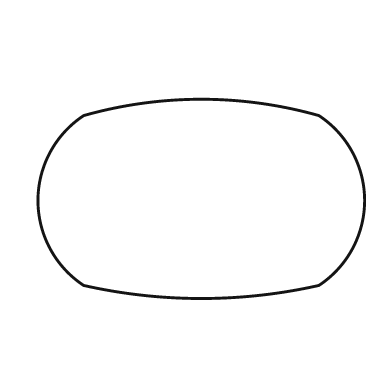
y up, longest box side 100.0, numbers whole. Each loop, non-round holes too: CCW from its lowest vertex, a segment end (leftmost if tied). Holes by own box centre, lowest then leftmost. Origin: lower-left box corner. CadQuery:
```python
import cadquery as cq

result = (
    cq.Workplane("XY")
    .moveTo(14.0, 4.0)
    .threePointArc((50.0, 0.0), (86.0, 4.0))
    .threePointArc((100.0, 30.0), (86.0, 56.0))
    .threePointArc((50.0, 61.0), (14.0, 56.0))
    .threePointArc((0.0, 30.0), (14.0, 4.0))
    .close()
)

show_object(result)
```